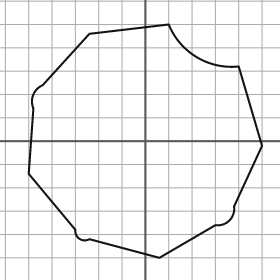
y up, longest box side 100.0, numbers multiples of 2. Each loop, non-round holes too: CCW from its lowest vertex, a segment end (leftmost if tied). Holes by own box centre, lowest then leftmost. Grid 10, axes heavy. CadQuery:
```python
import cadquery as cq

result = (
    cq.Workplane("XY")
    .moveTo(6.0, -50.0)
    .lineTo(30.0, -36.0)
    .threePointArc((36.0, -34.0), (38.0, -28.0))
    .lineTo(50.0, -2.0)
    .lineTo(40.0, 32.0)
    .threePointArc((22.0, 36.0), (10.0, 50.0))
    .lineTo(-24.0, 46.0)
    .lineTo(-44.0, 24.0)
    .threePointArc((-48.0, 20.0), (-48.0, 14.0))
    .lineTo(-50.0, -14.0)
    .lineTo(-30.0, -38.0)
    .threePointArc((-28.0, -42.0), (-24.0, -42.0))
    .close()
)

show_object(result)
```